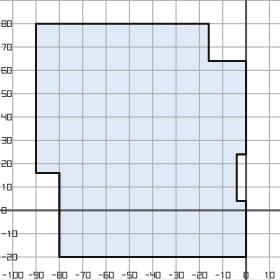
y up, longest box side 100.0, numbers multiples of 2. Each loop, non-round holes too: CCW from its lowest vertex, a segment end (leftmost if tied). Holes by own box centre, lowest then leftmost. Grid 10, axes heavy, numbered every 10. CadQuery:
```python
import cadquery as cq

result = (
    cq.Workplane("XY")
    .moveTo(-80.0, -20.0)
    .lineTo(0.0, -20.0)
    .lineTo(0.0, 4.0)
    .lineTo(-4.0, 4.0)
    .lineTo(-4.0, 24.0)
    .lineTo(0.0, 24.0)
    .lineTo(0.0, 64.0)
    .lineTo(-16.0, 64.0)
    .lineTo(-16.0, 80.0)
    .lineTo(-90.0, 80.0)
    .lineTo(-90.0, 16.0)
    .lineTo(-80.0, 16.0)
    .close()
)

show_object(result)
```